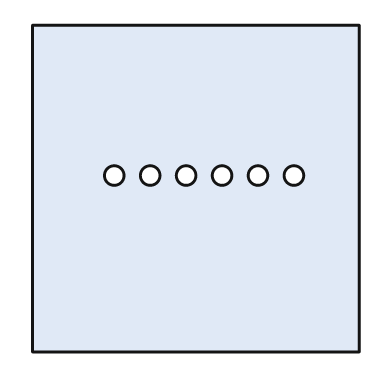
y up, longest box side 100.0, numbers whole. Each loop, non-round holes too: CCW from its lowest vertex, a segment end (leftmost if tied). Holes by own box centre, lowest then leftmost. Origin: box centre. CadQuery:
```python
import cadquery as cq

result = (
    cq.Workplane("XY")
    .moveTo(-50.0, -50.0)
    .lineTo(50.0, -50.0)
    .lineTo(50.0, 50.0)
    .lineTo(-50.0, 50.0)
    .close()
    .moveTo(-25.0, 4.0)
    .circle(3.0)
    .moveTo(-14.0, 4.0)
    .circle(3.0)
    .moveTo(-3.0, 4.0)
    .circle(3.0)
    .moveTo(8.0, 4.0)
    .circle(3.0)
    .moveTo(19.0, 4.0)
    .circle(3.0)
    .moveTo(30.0, 4.0)
    .circle(3.0)
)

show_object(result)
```